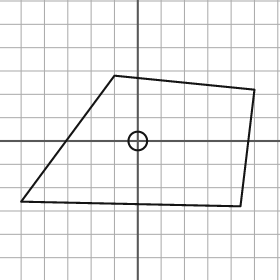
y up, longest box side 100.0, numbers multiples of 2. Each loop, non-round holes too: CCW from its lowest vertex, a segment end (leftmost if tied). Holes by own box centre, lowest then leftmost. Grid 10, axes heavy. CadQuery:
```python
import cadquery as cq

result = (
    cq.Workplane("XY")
    .moveTo(44.0, -28.0)
    .lineTo(50.0, 22.0)
    .lineTo(-10.0, 28.0)
    .lineTo(-50.0, -26.0)
    .close()
    .moveTo(0.0, 0.0)
    .circle(4.0)
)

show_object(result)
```